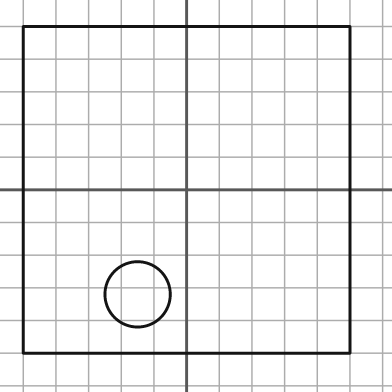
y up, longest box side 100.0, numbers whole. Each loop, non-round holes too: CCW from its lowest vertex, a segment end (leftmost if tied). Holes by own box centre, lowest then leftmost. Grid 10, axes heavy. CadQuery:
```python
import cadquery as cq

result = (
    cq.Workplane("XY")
    .moveTo(-50.0, -50.0)
    .lineTo(50.0, -50.0)
    .lineTo(50.0, 50.0)
    .lineTo(-50.0, 50.0)
    .close()
    .moveTo(-15.0, -32.0)
    .circle(10.0)
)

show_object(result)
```